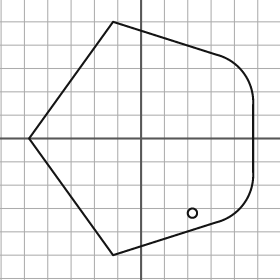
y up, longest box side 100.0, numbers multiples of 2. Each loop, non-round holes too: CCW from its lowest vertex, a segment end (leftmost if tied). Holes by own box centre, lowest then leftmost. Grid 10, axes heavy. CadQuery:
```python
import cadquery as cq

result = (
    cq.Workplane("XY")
    .moveTo(-12.0, -50.0)
    .lineTo(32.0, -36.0)
    .threePointArc((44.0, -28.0), (48.0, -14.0))
    .lineTo(48.0, 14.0)
    .threePointArc((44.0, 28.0), (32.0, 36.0))
    .lineTo(-12.0, 50.0)
    .lineTo(-48.0, 0.0)
    .close()
    .moveTo(22.0, -32.0)
    .circle(2.0)
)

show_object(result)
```